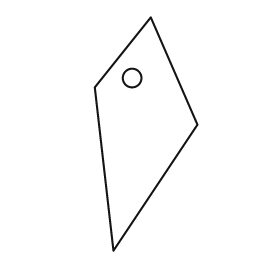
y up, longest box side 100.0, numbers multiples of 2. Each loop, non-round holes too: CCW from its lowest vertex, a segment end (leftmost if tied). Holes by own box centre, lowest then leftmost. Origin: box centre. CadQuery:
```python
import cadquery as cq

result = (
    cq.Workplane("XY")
    .moveTo(-14.0, -50.0)
    .lineTo(22.0, 4.0)
    .lineTo(2.0, 50.0)
    .lineTo(-22.0, 20.0)
    .close()
    .moveTo(-6.0, 24.0)
    .circle(4.0)
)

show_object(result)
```